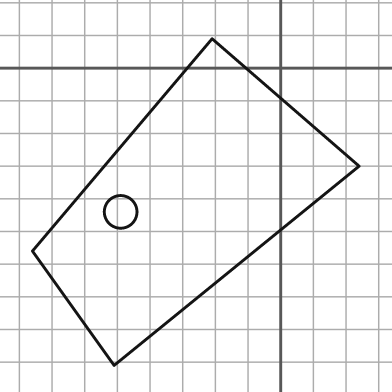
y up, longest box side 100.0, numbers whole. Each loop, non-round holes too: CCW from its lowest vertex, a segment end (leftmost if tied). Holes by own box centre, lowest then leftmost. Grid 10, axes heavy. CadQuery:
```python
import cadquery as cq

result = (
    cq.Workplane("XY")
    .moveTo(-51.0, -91.0)
    .lineTo(24.0, -30.0)
    .lineTo(-21.0, 9.0)
    .lineTo(-76.0, -56.0)
    .close()
    .moveTo(-49.0, -44.0)
    .circle(5.0)
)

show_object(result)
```